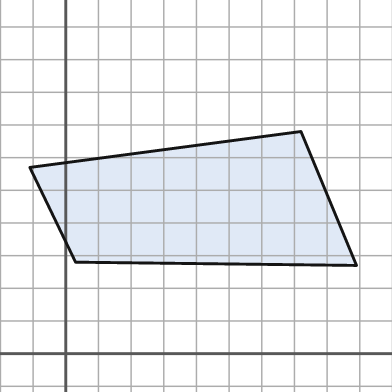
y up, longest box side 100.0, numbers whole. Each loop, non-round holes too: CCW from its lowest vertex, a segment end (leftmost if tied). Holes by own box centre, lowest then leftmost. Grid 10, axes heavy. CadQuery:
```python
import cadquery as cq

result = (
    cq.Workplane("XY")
    .moveTo(89.0, 27.0)
    .lineTo(72.0, 68.0)
    .lineTo(-11.0, 57.0)
    .lineTo(3.0, 28.0)
    .close()
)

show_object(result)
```